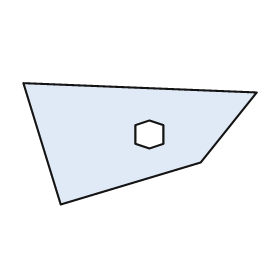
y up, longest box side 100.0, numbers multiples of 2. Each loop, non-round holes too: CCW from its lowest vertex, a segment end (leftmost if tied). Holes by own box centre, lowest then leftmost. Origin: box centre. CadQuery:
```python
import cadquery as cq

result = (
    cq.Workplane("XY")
    .moveTo(-34.0, -26.0)
    .lineTo(26.0, -8.0)
    .lineTo(50.0, 22.0)
    .lineTo(-50.0, 26.0)
    .close()
    .moveTo(4.0, -2.0)
    .lineTo(10.0, 0.0)
    .lineTo(10.0, 8.0)
    .lineTo(4.0, 10.0)
    .lineTo(-2.0, 8.0)
    .lineTo(-2.0, 0.0)
    .close()
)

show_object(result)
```